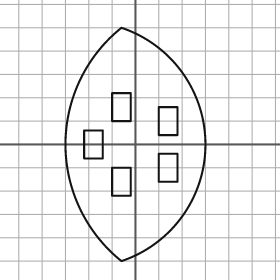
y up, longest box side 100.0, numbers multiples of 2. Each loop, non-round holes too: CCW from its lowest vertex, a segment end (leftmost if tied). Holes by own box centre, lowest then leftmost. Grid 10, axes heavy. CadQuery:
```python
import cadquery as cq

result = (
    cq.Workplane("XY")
    .moveTo(-6.0, -50.0)
    .threePointArc((30.0, 0.0), (-6.0, 50.0))
    .threePointArc((-30.0, 0.0), (-6.0, -50.0))
    .close()
    .moveTo(-10.0, -22.0)
    .lineTo(-2.0, -22.0)
    .lineTo(-2.0, -10.0)
    .lineTo(-10.0, -10.0)
    .close()
    .moveTo(10.0, -16.0)
    .lineTo(18.0, -16.0)
    .lineTo(18.0, -4.0)
    .lineTo(10.0, -4.0)
    .close()
    .moveTo(-22.0, -6.0)
    .lineTo(-14.0, -6.0)
    .lineTo(-14.0, 6.0)
    .lineTo(-22.0, 6.0)
    .close()
    .moveTo(10.0, 4.0)
    .lineTo(18.0, 4.0)
    .lineTo(18.0, 16.0)
    .lineTo(10.0, 16.0)
    .close()
    .moveTo(-10.0, 10.0)
    .lineTo(-2.0, 10.0)
    .lineTo(-2.0, 22.0)
    .lineTo(-10.0, 22.0)
    .close()
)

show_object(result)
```